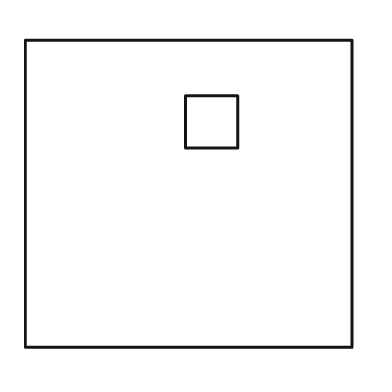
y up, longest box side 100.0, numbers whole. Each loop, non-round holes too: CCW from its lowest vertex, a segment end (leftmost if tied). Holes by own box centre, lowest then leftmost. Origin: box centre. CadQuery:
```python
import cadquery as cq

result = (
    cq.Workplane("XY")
    .moveTo(-50.0, -47.0)
    .lineTo(50.0, -47.0)
    .lineTo(50.0, 47.0)
    .lineTo(-50.0, 47.0)
    .close()
    .moveTo(-1.0, 14.0)
    .lineTo(15.0, 14.0)
    .lineTo(15.0, 30.0)
    .lineTo(-1.0, 30.0)
    .close()
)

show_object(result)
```